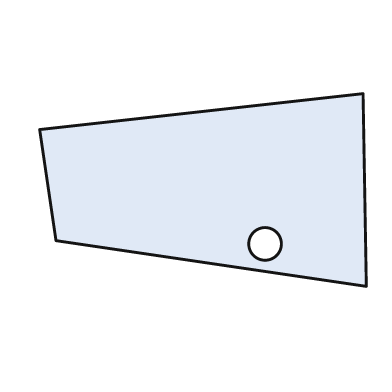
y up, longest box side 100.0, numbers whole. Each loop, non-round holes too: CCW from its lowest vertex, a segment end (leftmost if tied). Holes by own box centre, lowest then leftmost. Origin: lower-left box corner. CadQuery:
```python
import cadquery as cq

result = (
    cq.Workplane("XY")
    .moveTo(100.0, 0.0)
    .lineTo(99.0, 59.0)
    .lineTo(0.0, 48.0)
    .lineTo(5.0, 14.0)
    .close()
    .moveTo(69.0, 13.0)
    .circle(5.0)
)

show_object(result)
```